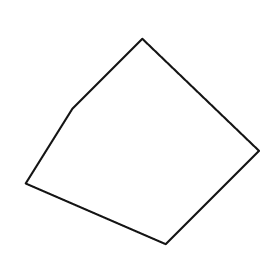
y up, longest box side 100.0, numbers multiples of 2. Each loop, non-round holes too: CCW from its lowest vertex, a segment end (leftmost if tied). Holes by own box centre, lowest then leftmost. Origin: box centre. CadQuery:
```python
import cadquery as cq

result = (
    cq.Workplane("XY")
    .moveTo(10.0, -44.0)
    .lineTo(50.0, -4.0)
    .lineTo(0.0, 44.0)
    .lineTo(-30.0, 14.0)
    .lineTo(-50.0, -18.0)
    .close()
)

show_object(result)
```